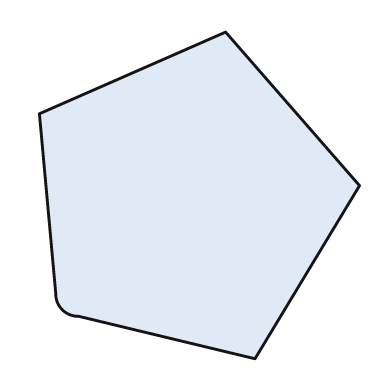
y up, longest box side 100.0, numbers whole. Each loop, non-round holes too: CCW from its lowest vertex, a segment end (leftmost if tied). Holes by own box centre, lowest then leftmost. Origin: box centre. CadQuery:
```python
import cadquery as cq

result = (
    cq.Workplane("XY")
    .moveTo(17.0, -50.0)
    .lineTo(49.0, 3.0)
    .lineTo(8.0, 50.0)
    .lineTo(-49.0, 25.0)
    .lineTo(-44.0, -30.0)
    .threePointArc((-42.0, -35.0), (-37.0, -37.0))
    .close()
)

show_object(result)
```